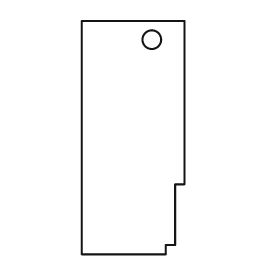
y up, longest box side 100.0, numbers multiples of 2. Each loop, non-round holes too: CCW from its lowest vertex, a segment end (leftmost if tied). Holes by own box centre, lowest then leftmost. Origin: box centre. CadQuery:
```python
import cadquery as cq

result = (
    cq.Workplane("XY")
    .moveTo(-22.0, -50.0)
    .lineTo(14.0, -50.0)
    .lineTo(14.0, -46.0)
    .lineTo(18.0, -46.0)
    .lineTo(18.0, -20.0)
    .lineTo(22.0, -20.0)
    .lineTo(22.0, 50.0)
    .lineTo(-22.0, 50.0)
    .close()
    .moveTo(8.0, 42.0)
    .circle(4.0)
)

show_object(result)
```